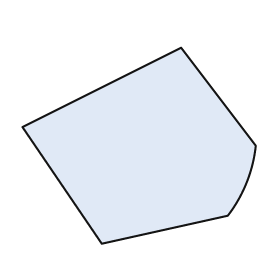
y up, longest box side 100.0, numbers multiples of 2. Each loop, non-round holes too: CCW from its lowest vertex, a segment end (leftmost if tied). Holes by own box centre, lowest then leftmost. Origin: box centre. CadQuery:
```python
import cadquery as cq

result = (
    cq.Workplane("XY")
    .moveTo(-16.0, -42.0)
    .lineTo(38.0, -30.0)
    .threePointArc((46.0, -16.0), (50.0, 0.0))
    .lineTo(18.0, 42.0)
    .lineTo(-50.0, 8.0)
    .close()
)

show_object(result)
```